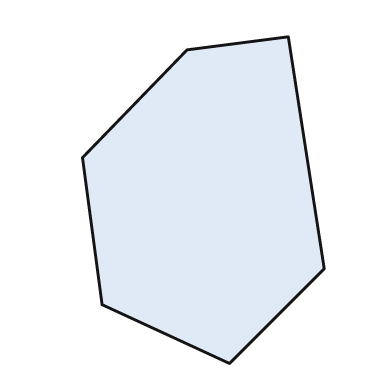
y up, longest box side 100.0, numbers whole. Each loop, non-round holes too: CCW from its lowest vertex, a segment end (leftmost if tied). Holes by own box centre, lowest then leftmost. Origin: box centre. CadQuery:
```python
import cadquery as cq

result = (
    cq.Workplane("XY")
    .moveTo(8.0, -50.0)
    .lineTo(37.0, -21.0)
    .lineTo(26.0, 50.0)
    .lineTo(-5.0, 46.0)
    .lineTo(-37.0, 13.0)
    .lineTo(-31.0, -32.0)
    .close()
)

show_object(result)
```